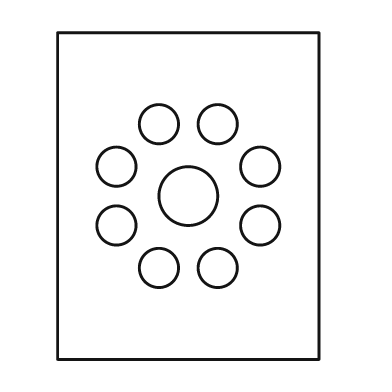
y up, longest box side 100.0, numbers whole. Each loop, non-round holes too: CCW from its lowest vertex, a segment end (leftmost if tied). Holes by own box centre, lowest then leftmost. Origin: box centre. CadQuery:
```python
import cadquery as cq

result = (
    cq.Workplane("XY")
    .moveTo(-40.0, -50.0)
    .lineTo(40.0, -50.0)
    .lineTo(40.0, 50.0)
    .lineTo(-40.0, 50.0)
    .close()
    .moveTo(-9.0, -22.0)
    .circle(6.0)
    .moveTo(9.0, -22.0)
    .circle(6.0)
    .moveTo(-22.0, -9.0)
    .circle(6.0)
    .moveTo(22.0, -9.0)
    .circle(6.0)
    .moveTo(0.0, 0.0)
    .circle(9.0)
    .moveTo(-22.0, 9.0)
    .circle(6.0)
    .moveTo(22.0, 9.0)
    .circle(6.0)
    .moveTo(-9.0, 22.0)
    .circle(6.0)
    .moveTo(9.0, 22.0)
    .circle(6.0)
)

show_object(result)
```